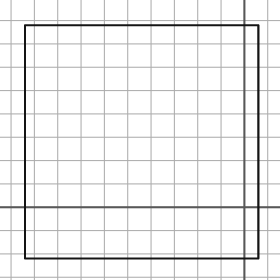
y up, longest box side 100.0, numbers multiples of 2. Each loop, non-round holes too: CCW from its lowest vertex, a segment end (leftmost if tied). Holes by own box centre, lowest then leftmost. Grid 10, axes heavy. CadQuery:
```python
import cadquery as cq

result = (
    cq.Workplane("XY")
    .moveTo(-94.0, -22.0)
    .lineTo(6.0, -22.0)
    .lineTo(6.0, 78.0)
    .lineTo(-94.0, 78.0)
    .close()
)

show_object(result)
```